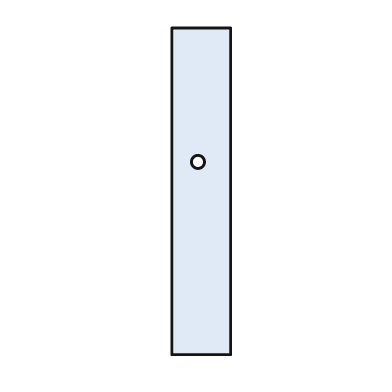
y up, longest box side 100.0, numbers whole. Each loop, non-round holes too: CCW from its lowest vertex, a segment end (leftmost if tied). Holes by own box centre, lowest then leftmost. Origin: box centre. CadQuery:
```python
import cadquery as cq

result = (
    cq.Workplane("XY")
    .moveTo(-9.0, -50.0)
    .lineTo(9.0, -50.0)
    .lineTo(9.0, 50.0)
    .lineTo(-9.0, 50.0)
    .close()
    .moveTo(-1.0, 9.0)
    .circle(2.0)
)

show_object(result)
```